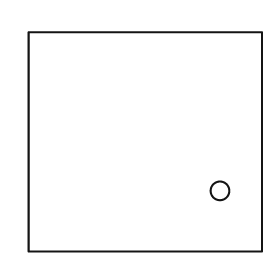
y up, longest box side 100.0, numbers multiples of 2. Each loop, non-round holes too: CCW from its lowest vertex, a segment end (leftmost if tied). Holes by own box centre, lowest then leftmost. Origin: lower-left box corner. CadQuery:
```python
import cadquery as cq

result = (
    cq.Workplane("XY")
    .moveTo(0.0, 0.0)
    .lineTo(100.0, 0.0)
    .lineTo(100.0, 94.0)
    .lineTo(0.0, 94.0)
    .close()
    .moveTo(82.0, 26.0)
    .circle(4.0)
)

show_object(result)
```